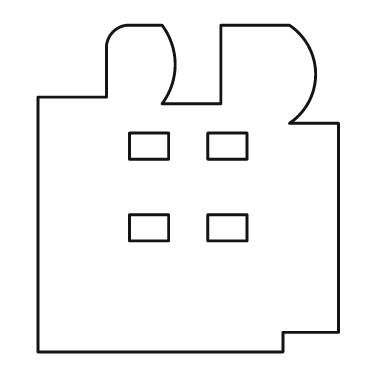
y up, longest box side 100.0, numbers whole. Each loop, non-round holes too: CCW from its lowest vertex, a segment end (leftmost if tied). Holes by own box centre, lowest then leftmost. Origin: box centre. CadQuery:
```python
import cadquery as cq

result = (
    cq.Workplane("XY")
    .moveTo(-46.0, -50.0)
    .lineTo(29.0, -50.0)
    .lineTo(29.0, -44.0)
    .lineTo(46.0, -44.0)
    .lineTo(46.0, 20.0)
    .lineTo(31.0, 20.0)
    .threePointArc((39.0, 35.0), (31.0, 50.0))
    .lineTo(10.0, 50.0)
    .lineTo(10.0, 26.0)
    .lineTo(-8.0, 26.0)
    .threePointArc((-4.0, 38.0), (-8.0, 50.0))
    .lineTo(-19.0, 50.0)
    .threePointArc((-23.0, 48.0), (-25.0, 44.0))
    .lineTo(-25.0, 28.0)
    .lineTo(-46.0, 28.0)
    .close()
    .moveTo(-18.0, -16.0)
    .lineTo(-6.0, -16.0)
    .lineTo(-6.0, -8.0)
    .lineTo(-18.0, -8.0)
    .close()
    .moveTo(6.0, -16.0)
    .lineTo(18.0, -16.0)
    .lineTo(18.0, -8.0)
    .lineTo(6.0, -8.0)
    .close()
    .moveTo(-18.0, 9.0)
    .lineTo(-6.0, 9.0)
    .lineTo(-6.0, 17.0)
    .lineTo(-18.0, 17.0)
    .close()
    .moveTo(6.0, 9.0)
    .lineTo(18.0, 9.0)
    .lineTo(18.0, 17.0)
    .lineTo(6.0, 17.0)
    .close()
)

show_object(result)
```